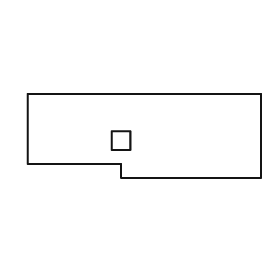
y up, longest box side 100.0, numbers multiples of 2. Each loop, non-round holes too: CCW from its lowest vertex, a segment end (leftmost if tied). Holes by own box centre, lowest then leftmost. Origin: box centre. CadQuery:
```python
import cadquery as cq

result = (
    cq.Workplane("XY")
    .moveTo(-10.0, -18.0)
    .lineTo(50.0, -18.0)
    .lineTo(50.0, 18.0)
    .lineTo(-50.0, 18.0)
    .lineTo(-50.0, -12.0)
    .lineTo(-10.0, -12.0)
    .close()
    .moveTo(-14.0, -6.0)
    .lineTo(-6.0, -6.0)
    .lineTo(-6.0, 2.0)
    .lineTo(-14.0, 2.0)
    .close()
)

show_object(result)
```